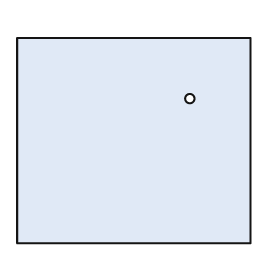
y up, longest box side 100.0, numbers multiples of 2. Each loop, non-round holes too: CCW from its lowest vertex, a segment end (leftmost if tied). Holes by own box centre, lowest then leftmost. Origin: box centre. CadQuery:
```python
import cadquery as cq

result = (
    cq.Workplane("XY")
    .moveTo(-50.0, -44.0)
    .lineTo(50.0, -44.0)
    .lineTo(50.0, 44.0)
    .lineTo(-50.0, 44.0)
    .close()
    .moveTo(24.0, 18.0)
    .circle(2.0)
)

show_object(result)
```